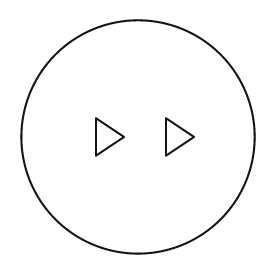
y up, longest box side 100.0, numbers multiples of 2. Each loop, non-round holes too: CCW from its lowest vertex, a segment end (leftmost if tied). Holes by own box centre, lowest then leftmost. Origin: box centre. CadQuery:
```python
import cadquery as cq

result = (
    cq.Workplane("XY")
    .moveTo(0.0, 0.0)
    .circle(50.0)
    .moveTo(-18.0, -8.0)
    .lineTo(-6.0, 0.0)
    .lineTo(-18.0, 8.0)
    .close()
    .moveTo(12.0, -8.0)
    .lineTo(24.0, 0.0)
    .lineTo(12.0, 8.0)
    .close()
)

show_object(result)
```